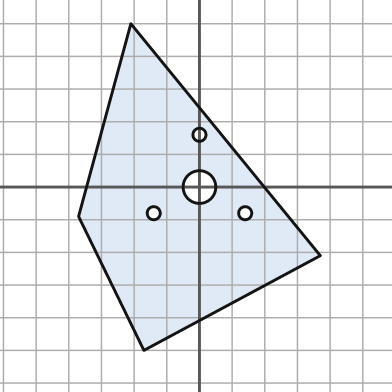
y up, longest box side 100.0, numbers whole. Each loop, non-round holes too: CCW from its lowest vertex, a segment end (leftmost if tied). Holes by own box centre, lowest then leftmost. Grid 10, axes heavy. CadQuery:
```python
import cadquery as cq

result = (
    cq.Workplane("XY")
    .moveTo(-17.0, -50.0)
    .lineTo(37.0, -21.0)
    .lineTo(-21.0, 50.0)
    .lineTo(-37.0, -9.0)
    .close()
    .moveTo(-14.0, -8.0)
    .circle(2.0)
    .moveTo(14.0, -8.0)
    .circle(2.0)
    .moveTo(0.0, 0.0)
    .circle(5.0)
    .moveTo(0.0, 16.0)
    .circle(2.0)
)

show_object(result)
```